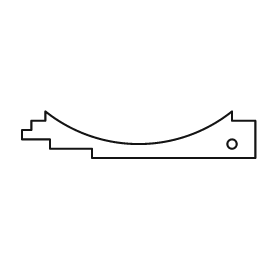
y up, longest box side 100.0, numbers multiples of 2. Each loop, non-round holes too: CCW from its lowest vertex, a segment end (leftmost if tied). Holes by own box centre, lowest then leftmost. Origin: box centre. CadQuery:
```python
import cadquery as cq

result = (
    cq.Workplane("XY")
    .moveTo(-20.0, -10.0)
    .lineTo(50.0, -10.0)
    .lineTo(50.0, 6.0)
    .lineTo(40.0, 6.0)
    .lineTo(40.0, 10.0)
    .threePointArc((0.0, -4.0), (-40.0, 10.0))
    .lineTo(-40.0, 6.0)
    .lineTo(-46.0, 6.0)
    .lineTo(-46.0, 2.0)
    .lineTo(-50.0, 2.0)
    .lineTo(-50.0, -2.0)
    .lineTo(-38.0, -2.0)
    .lineTo(-38.0, -6.0)
    .lineTo(-20.0, -6.0)
    .close()
    .moveTo(40.0, -4.0)
    .circle(2.0)
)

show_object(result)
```